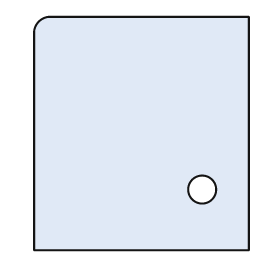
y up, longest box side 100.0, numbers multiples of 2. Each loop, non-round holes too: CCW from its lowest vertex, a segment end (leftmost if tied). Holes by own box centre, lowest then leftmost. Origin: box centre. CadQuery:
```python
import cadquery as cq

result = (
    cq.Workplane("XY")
    .moveTo(-46.0, -50.0)
    .lineTo(46.0, -50.0)
    .lineTo(46.0, 50.0)
    .lineTo(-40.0, 50.0)
    .threePointArc((-44.0, 48.0), (-46.0, 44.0))
    .close()
    .moveTo(26.0, -24.0)
    .circle(6.0)
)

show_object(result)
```